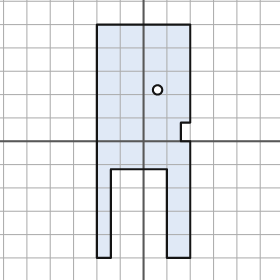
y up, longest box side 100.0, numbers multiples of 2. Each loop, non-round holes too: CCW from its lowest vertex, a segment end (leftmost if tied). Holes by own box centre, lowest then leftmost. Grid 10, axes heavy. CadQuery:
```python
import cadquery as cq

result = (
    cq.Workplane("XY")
    .moveTo(-20.0, -50.0)
    .lineTo(-14.0, -50.0)
    .lineTo(-14.0, -12.0)
    .lineTo(10.0, -12.0)
    .lineTo(10.0, -50.0)
    .lineTo(20.0, -50.0)
    .lineTo(20.0, 0.0)
    .lineTo(16.0, 0.0)
    .lineTo(16.0, 8.0)
    .lineTo(20.0, 8.0)
    .lineTo(20.0, 50.0)
    .lineTo(-20.0, 50.0)
    .close()
    .moveTo(6.0, 22.0)
    .circle(2.0)
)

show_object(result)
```